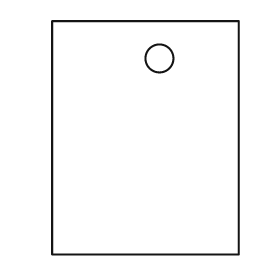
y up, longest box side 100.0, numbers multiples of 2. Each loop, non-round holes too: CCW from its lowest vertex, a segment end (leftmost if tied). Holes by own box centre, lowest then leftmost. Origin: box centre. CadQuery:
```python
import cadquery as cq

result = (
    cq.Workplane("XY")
    .moveTo(-40.0, -50.0)
    .lineTo(40.0, -50.0)
    .lineTo(40.0, 50.0)
    .lineTo(-40.0, 50.0)
    .close()
    .moveTo(6.0, 34.0)
    .circle(6.0)
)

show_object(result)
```